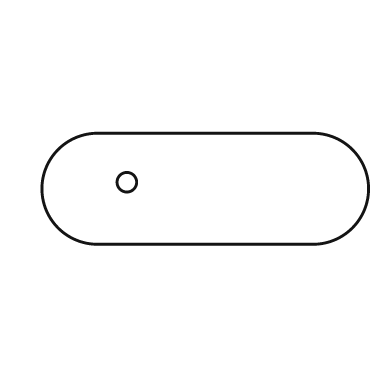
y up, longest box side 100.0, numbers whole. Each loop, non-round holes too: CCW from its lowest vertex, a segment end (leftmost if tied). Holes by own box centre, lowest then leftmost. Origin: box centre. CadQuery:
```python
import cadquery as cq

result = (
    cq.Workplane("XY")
    .moveTo(-33.0, -17.0)
    .lineTo(33.0, -17.0)
    .threePointArc((50.0, 0.0), (33.0, 17.0))
    .lineTo(-33.0, 17.0)
    .threePointArc((-50.0, 0.0), (-33.0, -17.0))
    .close()
    .moveTo(-24.0, 2.0)
    .circle(3.0)
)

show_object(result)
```